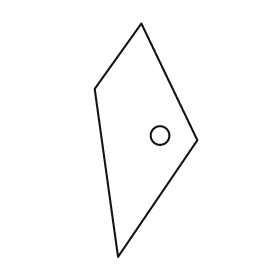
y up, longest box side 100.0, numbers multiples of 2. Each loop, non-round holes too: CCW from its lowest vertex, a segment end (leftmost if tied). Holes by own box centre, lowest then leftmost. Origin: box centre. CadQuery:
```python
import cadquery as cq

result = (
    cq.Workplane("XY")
    .moveTo(-12.0, -50.0)
    .lineTo(22.0, 0.0)
    .lineTo(-2.0, 50.0)
    .lineTo(-22.0, 22.0)
    .close()
    .moveTo(6.0, 2.0)
    .circle(4.0)
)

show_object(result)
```